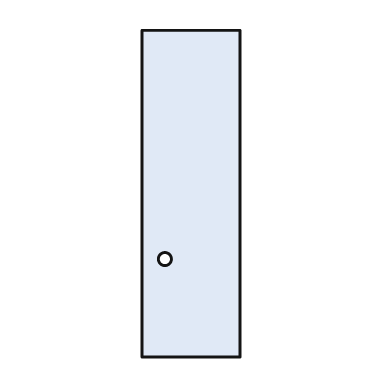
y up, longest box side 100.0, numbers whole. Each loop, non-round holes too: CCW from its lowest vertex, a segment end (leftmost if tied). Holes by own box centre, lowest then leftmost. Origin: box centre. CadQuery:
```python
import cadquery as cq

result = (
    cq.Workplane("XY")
    .moveTo(-15.0, -50.0)
    .lineTo(15.0, -50.0)
    .lineTo(15.0, 50.0)
    .lineTo(-15.0, 50.0)
    .close()
    .moveTo(-8.0, -20.0)
    .circle(2.0)
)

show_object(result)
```